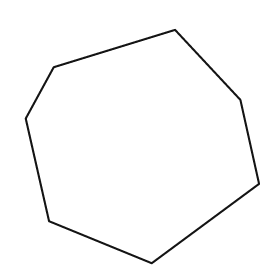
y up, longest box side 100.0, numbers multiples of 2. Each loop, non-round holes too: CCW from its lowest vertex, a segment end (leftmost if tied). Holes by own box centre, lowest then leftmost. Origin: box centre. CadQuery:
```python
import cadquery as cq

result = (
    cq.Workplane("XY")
    .moveTo(4.0, -50.0)
    .lineTo(50.0, -16.0)
    .lineTo(42.0, 20.0)
    .lineTo(14.0, 50.0)
    .lineTo(-38.0, 34.0)
    .lineTo(-50.0, 12.0)
    .lineTo(-40.0, -32.0)
    .close()
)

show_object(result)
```